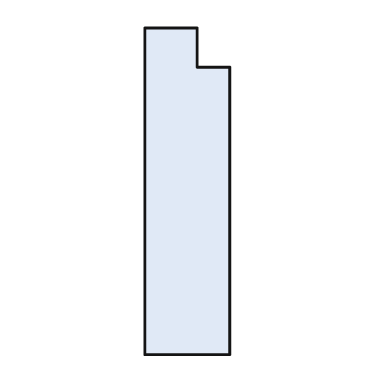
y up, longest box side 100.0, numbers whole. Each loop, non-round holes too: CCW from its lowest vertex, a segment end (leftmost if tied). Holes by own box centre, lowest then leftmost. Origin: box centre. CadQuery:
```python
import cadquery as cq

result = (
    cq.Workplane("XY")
    .moveTo(-13.0, -50.0)
    .lineTo(13.0, -50.0)
    .lineTo(13.0, 38.0)
    .lineTo(3.0, 38.0)
    .lineTo(3.0, 50.0)
    .lineTo(-13.0, 50.0)
    .close()
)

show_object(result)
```